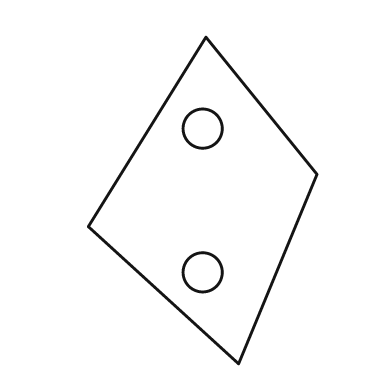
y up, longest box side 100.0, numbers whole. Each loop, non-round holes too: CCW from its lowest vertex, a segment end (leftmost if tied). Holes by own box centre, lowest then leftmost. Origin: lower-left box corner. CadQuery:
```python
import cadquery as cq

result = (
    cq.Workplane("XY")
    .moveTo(46.0, 0.0)
    .lineTo(70.0, 58.0)
    .lineTo(36.0, 100.0)
    .lineTo(0.0, 42.0)
    .close()
    .moveTo(35.0, 28.0)
    .circle(6.0)
    .moveTo(35.0, 72.0)
    .circle(6.0)
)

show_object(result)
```